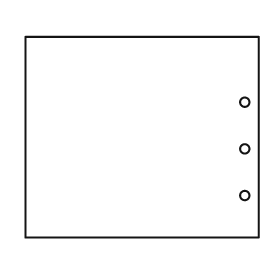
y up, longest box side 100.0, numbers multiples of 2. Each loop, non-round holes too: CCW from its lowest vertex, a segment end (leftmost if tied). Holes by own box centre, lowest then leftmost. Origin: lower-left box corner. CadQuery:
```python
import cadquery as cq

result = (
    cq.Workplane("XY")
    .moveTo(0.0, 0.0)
    .lineTo(100.0, 0.0)
    .lineTo(100.0, 86.0)
    .lineTo(0.0, 86.0)
    .close()
    .moveTo(94.0, 18.0)
    .circle(2.0)
    .moveTo(94.0, 38.0)
    .circle(2.0)
    .moveTo(94.0, 58.0)
    .circle(2.0)
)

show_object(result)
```